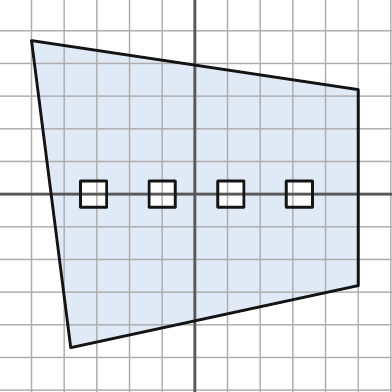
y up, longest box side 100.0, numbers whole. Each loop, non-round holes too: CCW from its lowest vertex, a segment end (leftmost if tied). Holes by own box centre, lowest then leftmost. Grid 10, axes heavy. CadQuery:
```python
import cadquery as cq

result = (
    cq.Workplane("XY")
    .moveTo(-38.0, -47.0)
    .lineTo(50.0, -28.0)
    .lineTo(50.0, 32.0)
    .lineTo(-50.0, 47.0)
    .close()
    .moveTo(-35.0, -4.0)
    .lineTo(-27.0, -4.0)
    .lineTo(-27.0, 4.0)
    .lineTo(-35.0, 4.0)
    .close()
    .moveTo(-14.0, -4.0)
    .lineTo(-6.0, -4.0)
    .lineTo(-6.0, 4.0)
    .lineTo(-14.0, 4.0)
    .close()
    .moveTo(7.0, -4.0)
    .lineTo(15.0, -4.0)
    .lineTo(15.0, 4.0)
    .lineTo(7.0, 4.0)
    .close()
    .moveTo(28.0, -4.0)
    .lineTo(36.0, -4.0)
    .lineTo(36.0, 4.0)
    .lineTo(28.0, 4.0)
    .close()
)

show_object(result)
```